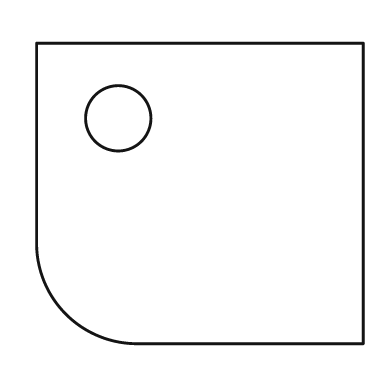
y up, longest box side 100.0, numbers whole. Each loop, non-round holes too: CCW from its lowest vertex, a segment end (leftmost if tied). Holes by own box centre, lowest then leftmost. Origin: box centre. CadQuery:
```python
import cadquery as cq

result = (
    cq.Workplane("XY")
    .moveTo(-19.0, -46.0)
    .lineTo(50.0, -46.0)
    .lineTo(50.0, 46.0)
    .lineTo(-50.0, 46.0)
    .lineTo(-50.0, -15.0)
    .threePointArc((-41.0, -37.0), (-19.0, -46.0))
    .close()
    .moveTo(-25.0, 23.0)
    .circle(10.0)
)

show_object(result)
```